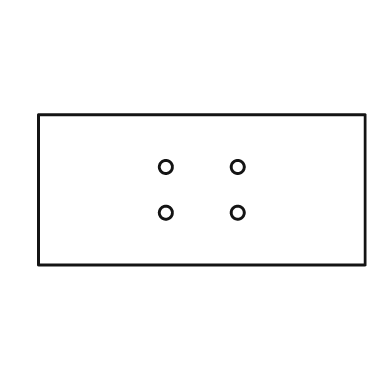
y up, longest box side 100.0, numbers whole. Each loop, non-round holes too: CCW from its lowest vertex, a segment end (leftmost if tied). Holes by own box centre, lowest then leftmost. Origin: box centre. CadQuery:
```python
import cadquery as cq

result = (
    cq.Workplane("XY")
    .moveTo(-50.0, -23.0)
    .lineTo(50.0, -23.0)
    .lineTo(50.0, 23.0)
    .lineTo(-50.0, 23.0)
    .close()
    .moveTo(-11.0, -7.0)
    .circle(2.0)
    .moveTo(11.0, -7.0)
    .circle(2.0)
    .moveTo(-11.0, 7.0)
    .circle(2.0)
    .moveTo(11.0, 7.0)
    .circle(2.0)
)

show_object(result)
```